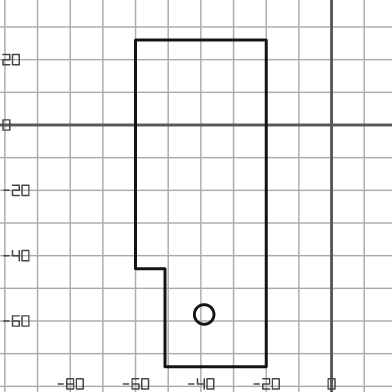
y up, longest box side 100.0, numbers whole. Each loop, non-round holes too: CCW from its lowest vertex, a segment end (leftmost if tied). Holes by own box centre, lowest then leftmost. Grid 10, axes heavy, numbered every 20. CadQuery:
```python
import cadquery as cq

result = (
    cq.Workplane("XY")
    .moveTo(-51.0, -74.0)
    .lineTo(-20.0, -74.0)
    .lineTo(-20.0, 26.0)
    .lineTo(-60.0, 26.0)
    .lineTo(-60.0, -44.0)
    .lineTo(-51.0, -44.0)
    .close()
    .moveTo(-39.0, -58.0)
    .circle(3.0)
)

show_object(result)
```